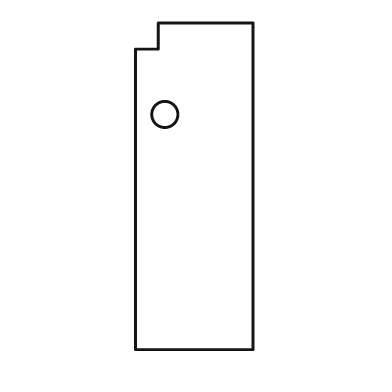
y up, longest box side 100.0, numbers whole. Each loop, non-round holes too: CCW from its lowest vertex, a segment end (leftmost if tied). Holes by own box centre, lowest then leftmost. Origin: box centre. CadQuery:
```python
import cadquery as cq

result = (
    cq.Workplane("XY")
    .moveTo(-18.0, -50.0)
    .lineTo(18.0, -50.0)
    .lineTo(18.0, 50.0)
    .lineTo(-11.0, 50.0)
    .lineTo(-11.0, 42.0)
    .lineTo(-18.0, 42.0)
    .close()
    .moveTo(-9.0, 22.0)
    .circle(4.0)
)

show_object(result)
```